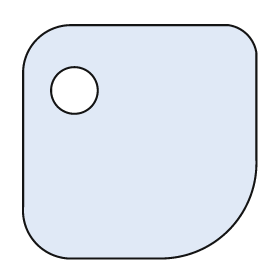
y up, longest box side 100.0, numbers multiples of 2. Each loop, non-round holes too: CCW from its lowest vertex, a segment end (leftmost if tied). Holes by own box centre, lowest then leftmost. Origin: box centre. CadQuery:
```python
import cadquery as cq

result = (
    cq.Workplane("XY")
    .moveTo(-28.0, -50.0)
    .lineTo(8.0, -50.0)
    .threePointArc((38.0, -38.0), (50.0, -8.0))
    .lineTo(50.0, 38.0)
    .threePointArc((46.0, 46.0), (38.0, 50.0))
    .lineTo(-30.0, 50.0)
    .threePointArc((-44.0, 44.0), (-50.0, 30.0))
    .lineTo(-50.0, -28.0)
    .threePointArc((-44.0, -44.0), (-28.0, -50.0))
    .close()
    .moveTo(-28.0, 22.0)
    .circle(10.0)
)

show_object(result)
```